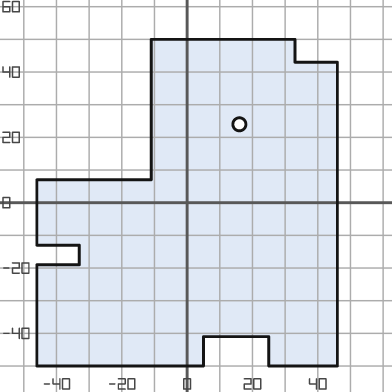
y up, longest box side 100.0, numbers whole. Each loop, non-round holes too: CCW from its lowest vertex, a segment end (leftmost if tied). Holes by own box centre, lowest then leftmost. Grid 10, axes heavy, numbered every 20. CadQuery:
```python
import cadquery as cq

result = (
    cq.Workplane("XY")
    .moveTo(-46.0, -50.0)
    .lineTo(5.0, -50.0)
    .lineTo(5.0, -41.0)
    .lineTo(25.0, -41.0)
    .lineTo(25.0, -50.0)
    .lineTo(46.0, -50.0)
    .lineTo(46.0, 43.0)
    .lineTo(33.0, 43.0)
    .lineTo(33.0, 50.0)
    .lineTo(-11.0, 50.0)
    .lineTo(-11.0, 7.0)
    .lineTo(-46.0, 7.0)
    .lineTo(-46.0, -13.0)
    .lineTo(-33.0, -13.0)
    .lineTo(-33.0, -19.0)
    .lineTo(-46.0, -19.0)
    .close()
    .moveTo(16.0, 24.0)
    .circle(2.0)
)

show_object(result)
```